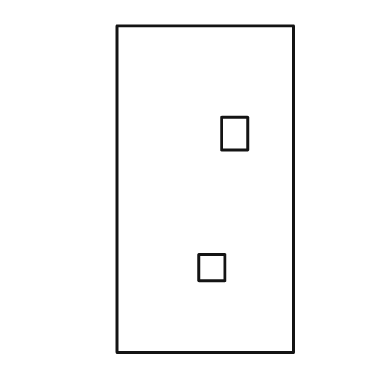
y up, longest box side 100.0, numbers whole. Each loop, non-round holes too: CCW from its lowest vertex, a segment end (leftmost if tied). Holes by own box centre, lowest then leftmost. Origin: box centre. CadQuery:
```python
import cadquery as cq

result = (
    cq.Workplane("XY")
    .moveTo(-27.0, -50.0)
    .lineTo(27.0, -50.0)
    .lineTo(27.0, 50.0)
    .lineTo(-27.0, 50.0)
    .close()
    .moveTo(-2.0, -28.0)
    .lineTo(6.0, -28.0)
    .lineTo(6.0, -20.0)
    .lineTo(-2.0, -20.0)
    .close()
    .moveTo(5.0, 12.0)
    .lineTo(13.0, 12.0)
    .lineTo(13.0, 22.0)
    .lineTo(5.0, 22.0)
    .close()
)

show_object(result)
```